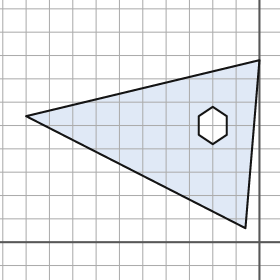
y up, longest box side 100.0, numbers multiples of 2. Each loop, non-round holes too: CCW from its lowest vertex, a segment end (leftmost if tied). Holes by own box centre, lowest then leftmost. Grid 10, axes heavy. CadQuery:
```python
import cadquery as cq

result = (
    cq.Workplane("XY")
    .moveTo(-6.0, 6.0)
    .lineTo(0.0, 78.0)
    .lineTo(-100.0, 54.0)
    .close()
    .moveTo(-20.0, 42.0)
    .lineTo(-14.0, 46.0)
    .lineTo(-14.0, 54.0)
    .lineTo(-20.0, 58.0)
    .lineTo(-26.0, 54.0)
    .lineTo(-26.0, 46.0)
    .close()
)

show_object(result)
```